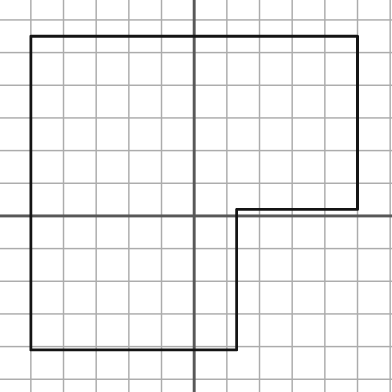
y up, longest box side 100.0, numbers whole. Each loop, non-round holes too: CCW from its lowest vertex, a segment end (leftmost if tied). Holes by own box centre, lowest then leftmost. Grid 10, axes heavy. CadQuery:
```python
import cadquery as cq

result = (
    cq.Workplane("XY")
    .moveTo(-50.0, -41.0)
    .lineTo(13.0, -41.0)
    .lineTo(13.0, 2.0)
    .lineTo(50.0, 2.0)
    .lineTo(50.0, 55.0)
    .lineTo(-50.0, 55.0)
    .close()
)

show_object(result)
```